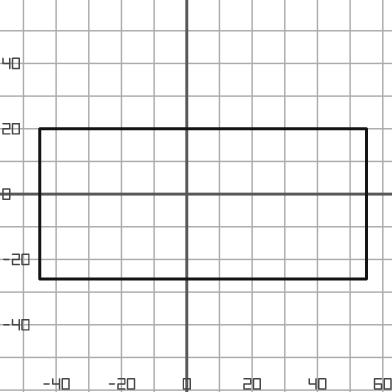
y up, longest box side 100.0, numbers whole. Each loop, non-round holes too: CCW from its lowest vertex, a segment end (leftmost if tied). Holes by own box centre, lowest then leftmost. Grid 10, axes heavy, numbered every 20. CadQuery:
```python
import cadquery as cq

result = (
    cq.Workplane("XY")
    .moveTo(-45.0, -26.0)
    .lineTo(55.0, -26.0)
    .lineTo(55.0, 20.0)
    .lineTo(-45.0, 20.0)
    .close()
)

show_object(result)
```